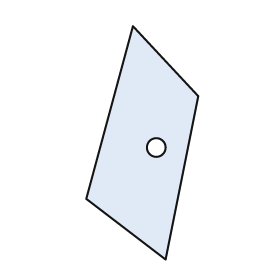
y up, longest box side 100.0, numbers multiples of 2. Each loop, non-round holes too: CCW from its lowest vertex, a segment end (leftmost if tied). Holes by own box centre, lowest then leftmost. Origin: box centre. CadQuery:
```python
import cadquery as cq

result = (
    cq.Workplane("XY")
    .moveTo(10.0, -50.0)
    .lineTo(24.0, 20.0)
    .lineTo(-4.0, 50.0)
    .lineTo(-24.0, -24.0)
    .close()
    .moveTo(6.0, -2.0)
    .circle(4.0)
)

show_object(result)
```